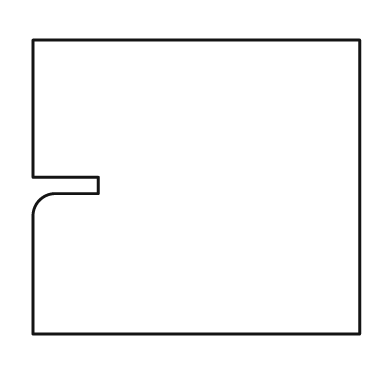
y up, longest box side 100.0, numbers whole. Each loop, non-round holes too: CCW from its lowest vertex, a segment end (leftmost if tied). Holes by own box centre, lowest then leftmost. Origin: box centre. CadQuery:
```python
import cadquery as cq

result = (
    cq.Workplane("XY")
    .moveTo(-50.0, -45.0)
    .lineTo(50.0, -45.0)
    .lineTo(50.0, 45.0)
    .lineTo(-50.0, 45.0)
    .lineTo(-50.0, 3.0)
    .lineTo(-30.0, 3.0)
    .lineTo(-30.0, -2.0)
    .lineTo(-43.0, -2.0)
    .threePointArc((-48.0, -4.0), (-50.0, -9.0))
    .close()
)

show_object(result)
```